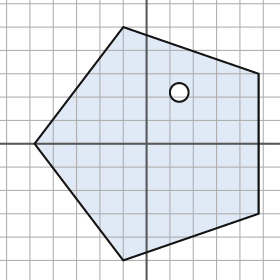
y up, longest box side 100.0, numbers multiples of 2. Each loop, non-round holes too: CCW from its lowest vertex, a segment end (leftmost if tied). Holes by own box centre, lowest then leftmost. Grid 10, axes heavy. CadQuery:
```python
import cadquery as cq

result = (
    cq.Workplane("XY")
    .moveTo(-10.0, -50.0)
    .lineTo(48.0, -30.0)
    .lineTo(48.0, 30.0)
    .lineTo(-10.0, 50.0)
    .lineTo(-48.0, 0.0)
    .close()
    .moveTo(14.0, 22.0)
    .circle(4.0)
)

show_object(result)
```